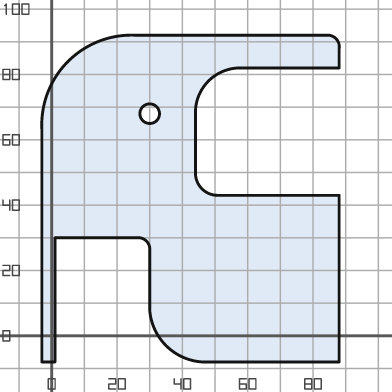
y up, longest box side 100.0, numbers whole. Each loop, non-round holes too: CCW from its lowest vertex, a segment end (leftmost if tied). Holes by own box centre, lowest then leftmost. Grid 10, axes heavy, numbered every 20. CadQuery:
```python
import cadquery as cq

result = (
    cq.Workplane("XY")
    .moveTo(-3.0, -8.0)
    .lineTo(1.0, -8.0)
    .lineTo(1.0, 30.0)
    .lineTo(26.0, 30.0)
    .threePointArc((29.0, 29.0), (30.0, 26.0))
    .lineTo(30.0, 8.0)
    .threePointArc((35.0, -3.0), (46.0, -8.0))
    .lineTo(88.0, -8.0)
    .lineTo(88.0, 43.0)
    .lineTo(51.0, 43.0)
    .threePointArc((46.0, 45.0), (44.0, 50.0))
    .lineTo(44.0, 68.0)
    .threePointArc((48.0, 78.0), (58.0, 82.0))
    .lineTo(88.0, 82.0)
    .lineTo(88.0, 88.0)
    .threePointArc((87.0, 91.0), (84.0, 92.0))
    .lineTo(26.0, 92.0)
    .threePointArc((5.0, 84.0), (-3.0, 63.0))
    .close()
    .moveTo(30.0, 68.0)
    .circle(3.0)
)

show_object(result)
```